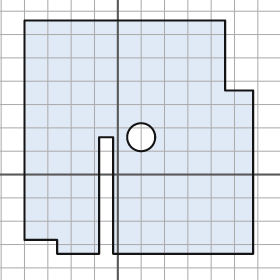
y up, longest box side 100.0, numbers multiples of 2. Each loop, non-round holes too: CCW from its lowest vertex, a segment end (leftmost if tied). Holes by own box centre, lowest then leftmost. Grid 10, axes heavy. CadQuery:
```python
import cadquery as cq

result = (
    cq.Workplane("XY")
    .moveTo(-26.0, -34.0)
    .lineTo(-8.0, -34.0)
    .lineTo(-8.0, 16.0)
    .lineTo(-2.0, 16.0)
    .lineTo(-2.0, -34.0)
    .lineTo(58.0, -34.0)
    .lineTo(58.0, 36.0)
    .lineTo(46.0, 36.0)
    .lineTo(46.0, 66.0)
    .lineTo(-40.0, 66.0)
    .lineTo(-40.0, -28.0)
    .lineTo(-26.0, -28.0)
    .close()
    .moveTo(10.0, 16.0)
    .circle(6.0)
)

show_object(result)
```